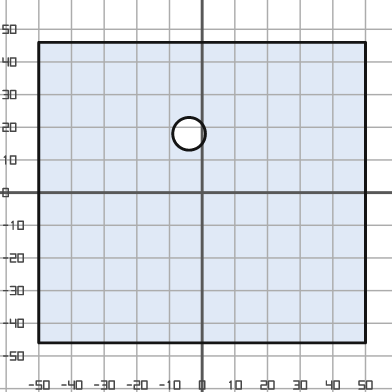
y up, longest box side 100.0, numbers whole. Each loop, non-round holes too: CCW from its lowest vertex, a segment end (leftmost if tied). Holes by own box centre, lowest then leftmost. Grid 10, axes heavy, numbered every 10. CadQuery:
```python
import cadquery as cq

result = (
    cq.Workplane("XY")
    .moveTo(-50.0, -46.0)
    .lineTo(50.0, -46.0)
    .lineTo(50.0, 46.0)
    .lineTo(-50.0, 46.0)
    .close()
    .moveTo(-4.0, 18.0)
    .circle(5.0)
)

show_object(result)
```